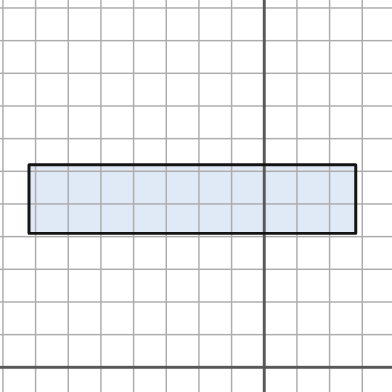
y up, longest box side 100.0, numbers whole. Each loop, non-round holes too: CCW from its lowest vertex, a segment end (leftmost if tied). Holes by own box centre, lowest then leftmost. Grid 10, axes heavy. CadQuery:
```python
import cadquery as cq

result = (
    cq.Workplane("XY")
    .moveTo(-72.0, 41.0)
    .lineTo(28.0, 41.0)
    .lineTo(28.0, 62.0)
    .lineTo(-72.0, 62.0)
    .close()
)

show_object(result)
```